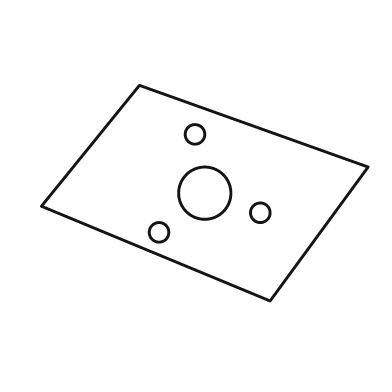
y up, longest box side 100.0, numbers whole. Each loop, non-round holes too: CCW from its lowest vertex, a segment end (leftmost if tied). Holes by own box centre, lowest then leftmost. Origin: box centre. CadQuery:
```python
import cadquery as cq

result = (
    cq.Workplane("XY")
    .moveTo(20.0, -33.0)
    .lineTo(50.0, 8.0)
    .lineTo(-20.0, 33.0)
    .lineTo(-50.0, -4.0)
    .close()
    .moveTo(-14.0, -12.0)
    .circle(3.0)
    .moveTo(17.0, -6.0)
    .circle(3.0)
    .moveTo(0.0, 0.0)
    .circle(8.0)
    .moveTo(-3.0, 18.0)
    .circle(3.0)
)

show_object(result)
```